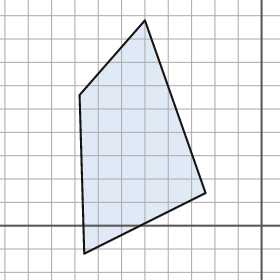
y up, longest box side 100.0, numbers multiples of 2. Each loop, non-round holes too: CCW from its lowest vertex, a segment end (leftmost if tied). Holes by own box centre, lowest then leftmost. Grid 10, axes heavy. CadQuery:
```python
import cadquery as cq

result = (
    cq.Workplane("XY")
    .moveTo(-76.0, -12.0)
    .lineTo(-24.0, 14.0)
    .lineTo(-50.0, 88.0)
    .lineTo(-78.0, 56.0)
    .close()
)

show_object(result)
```